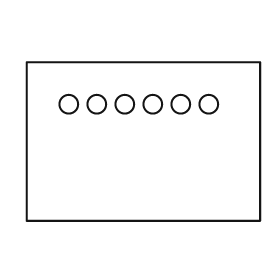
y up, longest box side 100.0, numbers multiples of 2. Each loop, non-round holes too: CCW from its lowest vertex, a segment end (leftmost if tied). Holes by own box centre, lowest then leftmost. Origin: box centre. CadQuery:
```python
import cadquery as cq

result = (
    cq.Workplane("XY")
    .moveTo(-50.0, -34.0)
    .lineTo(50.0, -34.0)
    .lineTo(50.0, 34.0)
    .lineTo(-50.0, 34.0)
    .close()
    .moveTo(-32.0, 16.0)
    .circle(4.0)
    .moveTo(-20.0, 16.0)
    .circle(4.0)
    .moveTo(-8.0, 16.0)
    .circle(4.0)
    .moveTo(4.0, 16.0)
    .circle(4.0)
    .moveTo(16.0, 16.0)
    .circle(4.0)
    .moveTo(28.0, 16.0)
    .circle(4.0)
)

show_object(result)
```